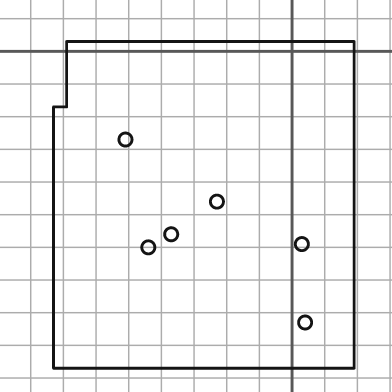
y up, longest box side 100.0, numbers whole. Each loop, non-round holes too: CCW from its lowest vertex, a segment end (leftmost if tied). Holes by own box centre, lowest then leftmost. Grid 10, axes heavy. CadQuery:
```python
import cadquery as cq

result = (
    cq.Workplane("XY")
    .moveTo(-73.0, -97.0)
    .lineTo(19.0, -97.0)
    .lineTo(19.0, 3.0)
    .lineTo(-69.0, 3.0)
    .lineTo(-69.0, -17.0)
    .lineTo(-73.0, -17.0)
    .close()
    .moveTo(4.0, -83.0)
    .circle(2.0)
    .moveTo(-44.0, -60.0)
    .circle(2.0)
    .moveTo(3.0, -59.0)
    .circle(2.0)
    .moveTo(-37.0, -56.0)
    .circle(2.0)
    .moveTo(-23.0, -46.0)
    .circle(2.0)
    .moveTo(-51.0, -27.0)
    .circle(2.0)
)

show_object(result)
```